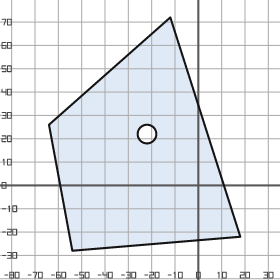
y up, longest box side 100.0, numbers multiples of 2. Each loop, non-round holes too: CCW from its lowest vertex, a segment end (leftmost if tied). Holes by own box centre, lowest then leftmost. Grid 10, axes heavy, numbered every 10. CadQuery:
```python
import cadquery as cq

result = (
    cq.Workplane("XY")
    .moveTo(-54.0, -28.0)
    .lineTo(18.0, -22.0)
    .lineTo(-12.0, 72.0)
    .lineTo(-64.0, 26.0)
    .close()
    .moveTo(-22.0, 22.0)
    .circle(4.0)
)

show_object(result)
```